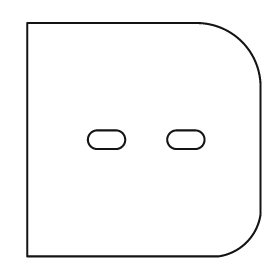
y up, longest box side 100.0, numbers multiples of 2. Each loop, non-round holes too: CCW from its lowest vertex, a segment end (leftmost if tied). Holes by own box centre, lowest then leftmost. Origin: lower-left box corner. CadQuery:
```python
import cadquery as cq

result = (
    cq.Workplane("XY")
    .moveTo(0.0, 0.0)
    .lineTo(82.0, 0.0)
    .threePointArc((94.0, 6.0), (100.0, 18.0))
    .lineTo(100.0, 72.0)
    .threePointArc((92.0, 92.0), (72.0, 100.0))
    .lineTo(0.0, 100.0)
    .close()
    .moveTo(30.0, 46.0)
    .lineTo(38.0, 46.0)
    .threePointArc((42.0, 50.0), (38.0, 54.0))
    .lineTo(30.0, 54.0)
    .threePointArc((26.0, 50.0), (30.0, 46.0))
    .close()
    .moveTo(64.0, 46.0)
    .lineTo(72.0, 46.0)
    .threePointArc((76.0, 50.0), (72.0, 54.0))
    .lineTo(64.0, 54.0)
    .threePointArc((60.0, 50.0), (64.0, 46.0))
    .close()
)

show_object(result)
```